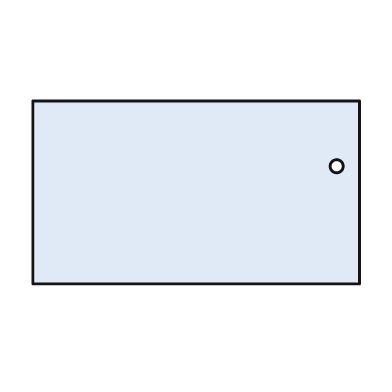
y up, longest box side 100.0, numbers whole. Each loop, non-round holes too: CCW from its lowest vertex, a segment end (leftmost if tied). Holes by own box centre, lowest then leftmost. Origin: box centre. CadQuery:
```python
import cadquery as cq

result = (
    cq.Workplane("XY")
    .moveTo(-50.0, -28.0)
    .lineTo(50.0, -28.0)
    .lineTo(50.0, 28.0)
    .lineTo(-50.0, 28.0)
    .close()
    .moveTo(43.0, 8.0)
    .circle(2.0)
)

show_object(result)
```